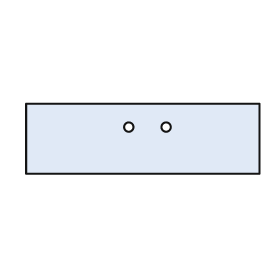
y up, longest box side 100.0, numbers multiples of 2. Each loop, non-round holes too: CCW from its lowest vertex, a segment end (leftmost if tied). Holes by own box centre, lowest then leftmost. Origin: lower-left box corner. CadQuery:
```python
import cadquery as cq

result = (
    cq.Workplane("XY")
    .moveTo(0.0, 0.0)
    .lineTo(100.0, 0.0)
    .lineTo(100.0, 30.0)
    .lineTo(0.0, 30.0)
    .close()
    .moveTo(44.0, 20.0)
    .circle(2.0)
    .moveTo(60.0, 20.0)
    .circle(2.0)
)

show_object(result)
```